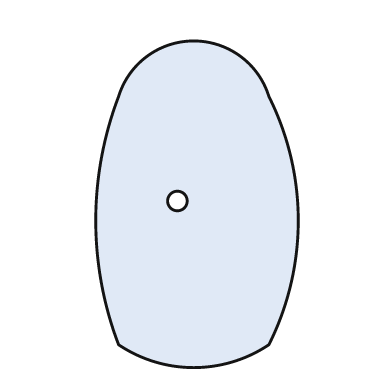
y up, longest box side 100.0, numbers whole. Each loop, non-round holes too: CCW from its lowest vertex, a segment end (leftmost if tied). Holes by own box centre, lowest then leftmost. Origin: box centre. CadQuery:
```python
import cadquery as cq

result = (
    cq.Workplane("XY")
    .moveTo(-24.0, -43.0)
    .threePointArc((-1.0, -50.0), (22.0, -43.0))
    .threePointArc((31.0, -5.0), (22.0, 33.0))
    .threePointArc((-1.0, 50.0), (-24.0, 33.0))
    .threePointArc((-31.0, -5.0), (-24.0, -43.0))
    .close()
    .moveTo(-6.0, 1.0)
    .circle(3.0)
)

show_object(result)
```